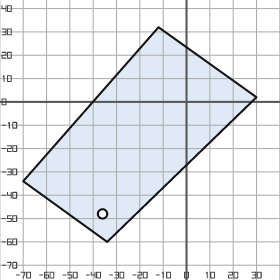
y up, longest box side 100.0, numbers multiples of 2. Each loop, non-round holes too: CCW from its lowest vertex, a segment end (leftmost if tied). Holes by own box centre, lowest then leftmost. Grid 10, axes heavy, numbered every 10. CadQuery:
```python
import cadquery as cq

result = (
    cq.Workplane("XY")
    .moveTo(-34.0, -60.0)
    .lineTo(30.0, 2.0)
    .lineTo(-12.0, 32.0)
    .lineTo(-70.0, -34.0)
    .close()
    .moveTo(-36.0, -48.0)
    .circle(2.0)
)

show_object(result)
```